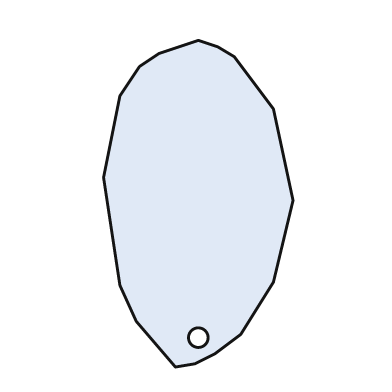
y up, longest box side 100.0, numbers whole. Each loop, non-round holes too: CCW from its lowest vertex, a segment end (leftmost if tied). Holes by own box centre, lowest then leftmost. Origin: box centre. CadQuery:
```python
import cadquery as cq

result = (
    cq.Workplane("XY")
    .moveTo(-7.0, -50.0)
    .lineTo(-1.0, -49.0)
    .lineTo(5.0, -46.0)
    .lineTo(13.0, -40.0)
    .lineTo(23.0, -24.0)
    .lineTo(29.0, 1.0)
    .lineTo(23.0, 29.0)
    .lineTo(11.0, 45.0)
    .lineTo(6.0, 48.0)
    .lineTo(0.0, 50.0)
    .lineTo(-12.0, 46.0)
    .lineTo(-18.0, 42.0)
    .lineTo(-24.0, 33.0)
    .lineTo(-29.0, 8.0)
    .lineTo(-24.0, -25.0)
    .lineTo(-19.0, -36.0)
    .close()
    .moveTo(0.0, -41.0)
    .circle(3.0)
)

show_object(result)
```